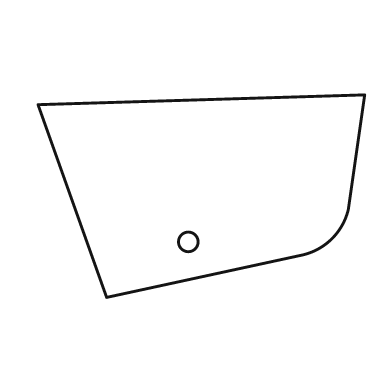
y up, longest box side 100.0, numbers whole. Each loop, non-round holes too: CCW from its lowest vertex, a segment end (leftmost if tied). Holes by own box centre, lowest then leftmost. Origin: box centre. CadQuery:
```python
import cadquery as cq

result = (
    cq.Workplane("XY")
    .moveTo(-29.0, -31.0)
    .lineTo(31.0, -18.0)
    .threePointArc((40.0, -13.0), (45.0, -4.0))
    .lineTo(50.0, 31.0)
    .lineTo(-50.0, 28.0)
    .close()
    .moveTo(-4.0, -14.0)
    .circle(3.0)
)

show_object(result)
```